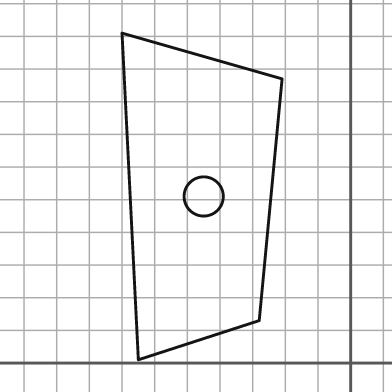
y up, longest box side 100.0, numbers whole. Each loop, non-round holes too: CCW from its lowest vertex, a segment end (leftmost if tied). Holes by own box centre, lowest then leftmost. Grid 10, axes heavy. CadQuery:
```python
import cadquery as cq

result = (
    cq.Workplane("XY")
    .moveTo(-65.0, 1.0)
    .lineTo(-28.0, 13.0)
    .lineTo(-21.0, 87.0)
    .lineTo(-70.0, 101.0)
    .close()
    .moveTo(-45.0, 51.0)
    .circle(6.0)
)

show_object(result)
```